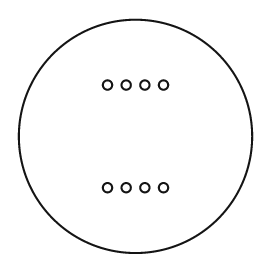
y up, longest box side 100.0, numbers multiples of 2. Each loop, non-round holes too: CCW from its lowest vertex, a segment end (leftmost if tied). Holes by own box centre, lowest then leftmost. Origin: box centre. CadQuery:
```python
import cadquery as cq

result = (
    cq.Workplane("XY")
    .moveTo(0.0, 0.0)
    .circle(50.0)
    .moveTo(-12.0, -22.0)
    .circle(2.0)
    .moveTo(-4.0, -22.0)
    .circle(2.0)
    .moveTo(4.0, -22.0)
    .circle(2.0)
    .moveTo(12.0, -22.0)
    .circle(2.0)
    .moveTo(-12.0, 22.0)
    .circle(2.0)
    .moveTo(-4.0, 22.0)
    .circle(2.0)
    .moveTo(4.0, 22.0)
    .circle(2.0)
    .moveTo(12.0, 22.0)
    .circle(2.0)
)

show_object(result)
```